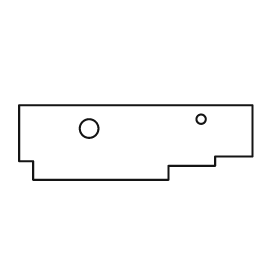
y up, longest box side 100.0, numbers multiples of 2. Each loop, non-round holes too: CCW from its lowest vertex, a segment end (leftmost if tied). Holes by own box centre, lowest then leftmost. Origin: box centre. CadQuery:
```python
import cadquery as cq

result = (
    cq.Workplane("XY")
    .moveTo(-44.0, -16.0)
    .lineTo(14.0, -16.0)
    .lineTo(14.0, -10.0)
    .lineTo(34.0, -10.0)
    .lineTo(34.0, -6.0)
    .lineTo(50.0, -6.0)
    .lineTo(50.0, 16.0)
    .lineTo(-50.0, 16.0)
    .lineTo(-50.0, -8.0)
    .lineTo(-44.0, -8.0)
    .close()
    .moveTo(-20.0, 6.0)
    .circle(4.0)
    .moveTo(28.0, 10.0)
    .circle(2.0)
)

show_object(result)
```